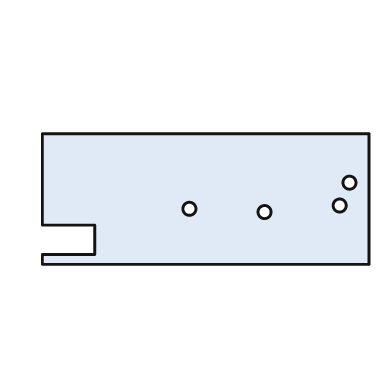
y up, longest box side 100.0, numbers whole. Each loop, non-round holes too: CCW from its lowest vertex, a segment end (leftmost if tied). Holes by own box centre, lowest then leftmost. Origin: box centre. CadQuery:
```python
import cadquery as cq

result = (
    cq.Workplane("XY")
    .moveTo(-50.0, -20.0)
    .lineTo(50.0, -20.0)
    .lineTo(50.0, 20.0)
    .lineTo(-50.0, 20.0)
    .lineTo(-50.0, -8.0)
    .lineTo(-34.0, -8.0)
    .lineTo(-34.0, -17.0)
    .lineTo(-50.0, -17.0)
    .close()
    .moveTo(18.0, -4.0)
    .circle(2.0)
    .moveTo(-5.0, -3.0)
    .circle(2.0)
    .moveTo(41.0, -2.0)
    .circle(2.0)
    .moveTo(44.0, 5.0)
    .circle(2.0)
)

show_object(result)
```